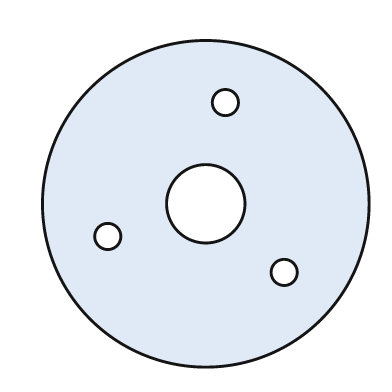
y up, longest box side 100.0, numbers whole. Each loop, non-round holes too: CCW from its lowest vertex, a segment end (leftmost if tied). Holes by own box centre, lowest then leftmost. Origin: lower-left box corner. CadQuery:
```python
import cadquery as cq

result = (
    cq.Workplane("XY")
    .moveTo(50.0, 50.0)
    .circle(50.0)
    .moveTo(74.0, 29.0)
    .circle(4.0)
    .moveTo(20.0, 40.0)
    .circle(4.0)
    .moveTo(50.0, 50.0)
    .circle(12.0)
    .moveTo(56.0, 81.0)
    .circle(4.0)
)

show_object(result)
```